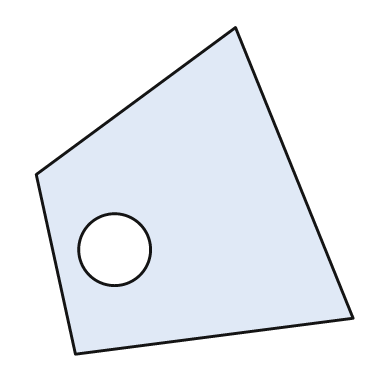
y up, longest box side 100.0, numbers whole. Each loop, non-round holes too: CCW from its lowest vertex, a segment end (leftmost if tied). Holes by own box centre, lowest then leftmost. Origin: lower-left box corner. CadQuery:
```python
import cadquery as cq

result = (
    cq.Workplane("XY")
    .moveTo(12.0, 0.0)
    .lineTo(97.0, 11.0)
    .lineTo(61.0, 100.0)
    .lineTo(0.0, 55.0)
    .close()
    .moveTo(24.0, 32.0)
    .circle(11.0)
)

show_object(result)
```